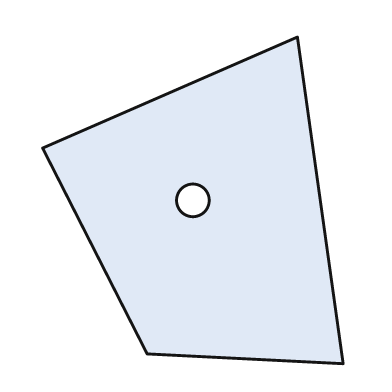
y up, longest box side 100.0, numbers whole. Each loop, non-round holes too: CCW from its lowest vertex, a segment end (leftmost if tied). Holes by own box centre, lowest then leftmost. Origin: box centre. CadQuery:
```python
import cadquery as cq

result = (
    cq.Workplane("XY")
    .moveTo(46.0, -50.0)
    .lineTo(32.0, 50.0)
    .lineTo(-46.0, 16.0)
    .lineTo(-14.0, -47.0)
    .close()
    .moveTo(0.0, 0.0)
    .circle(5.0)
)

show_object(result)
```